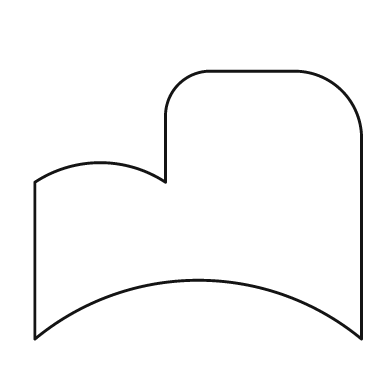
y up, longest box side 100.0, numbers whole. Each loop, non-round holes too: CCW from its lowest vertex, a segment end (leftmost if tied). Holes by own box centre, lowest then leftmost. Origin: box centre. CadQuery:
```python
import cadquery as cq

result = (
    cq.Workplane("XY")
    .moveTo(-50.0, -41.0)
    .threePointArc((0.0, -23.0), (50.0, -41.0))
    .lineTo(50.0, 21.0)
    .threePointArc((44.0, 35.0), (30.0, 41.0))
    .lineTo(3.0, 41.0)
    .threePointArc((-6.0, 37.0), (-10.0, 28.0))
    .lineTo(-10.0, 7.0)
    .threePointArc((-30.0, 13.0), (-50.0, 7.0))
    .close()
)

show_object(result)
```